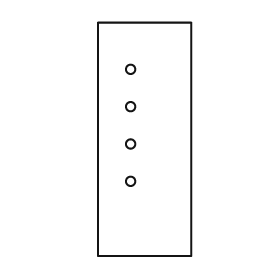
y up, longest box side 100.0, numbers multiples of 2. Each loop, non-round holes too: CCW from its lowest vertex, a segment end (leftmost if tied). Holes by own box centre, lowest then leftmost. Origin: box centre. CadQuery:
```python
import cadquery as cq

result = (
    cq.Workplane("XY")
    .moveTo(-20.0, -50.0)
    .lineTo(20.0, -50.0)
    .lineTo(20.0, 50.0)
    .lineTo(-20.0, 50.0)
    .close()
    .moveTo(-6.0, -18.0)
    .circle(2.0)
    .moveTo(-6.0, -2.0)
    .circle(2.0)
    .moveTo(-6.0, 14.0)
    .circle(2.0)
    .moveTo(-6.0, 30.0)
    .circle(2.0)
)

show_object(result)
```